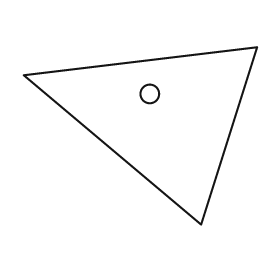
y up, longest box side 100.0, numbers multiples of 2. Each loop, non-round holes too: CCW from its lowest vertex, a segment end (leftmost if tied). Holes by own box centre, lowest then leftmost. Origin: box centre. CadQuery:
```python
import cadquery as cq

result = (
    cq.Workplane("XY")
    .moveTo(26.0, -38.0)
    .lineTo(50.0, 38.0)
    .lineTo(-50.0, 26.0)
    .close()
    .moveTo(4.0, 18.0)
    .circle(4.0)
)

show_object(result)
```